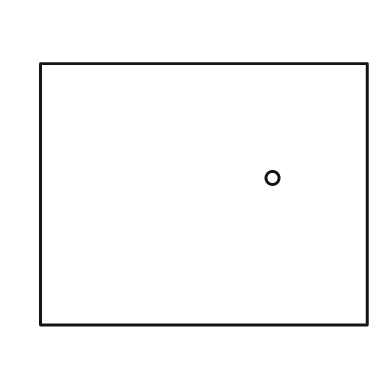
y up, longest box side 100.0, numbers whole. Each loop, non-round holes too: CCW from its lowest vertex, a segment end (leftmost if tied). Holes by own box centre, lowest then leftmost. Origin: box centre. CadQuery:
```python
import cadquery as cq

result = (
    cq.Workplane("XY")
    .moveTo(-50.0, -40.0)
    .lineTo(50.0, -40.0)
    .lineTo(50.0, 40.0)
    .lineTo(-50.0, 40.0)
    .close()
    .moveTo(21.0, 5.0)
    .circle(2.0)
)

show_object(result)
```